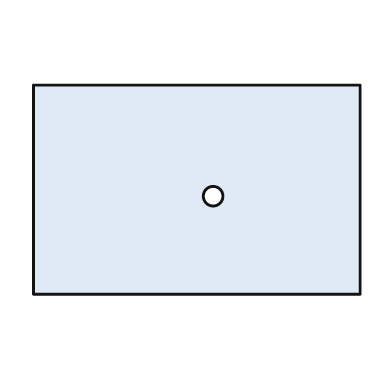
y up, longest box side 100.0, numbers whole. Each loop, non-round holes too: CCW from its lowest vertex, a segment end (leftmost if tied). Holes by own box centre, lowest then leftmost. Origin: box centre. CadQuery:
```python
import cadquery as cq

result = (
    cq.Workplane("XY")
    .moveTo(-50.0, -32.0)
    .lineTo(50.0, -32.0)
    .lineTo(50.0, 32.0)
    .lineTo(-50.0, 32.0)
    .close()
    .moveTo(5.0, -2.0)
    .circle(3.0)
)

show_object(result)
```